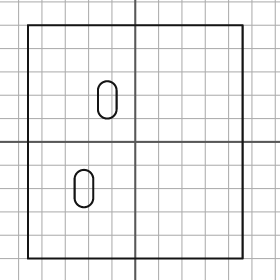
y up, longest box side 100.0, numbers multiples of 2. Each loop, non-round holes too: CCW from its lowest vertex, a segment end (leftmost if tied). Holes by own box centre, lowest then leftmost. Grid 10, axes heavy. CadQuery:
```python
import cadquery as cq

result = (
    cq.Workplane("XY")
    .moveTo(-46.0, -50.0)
    .lineTo(46.0, -50.0)
    .lineTo(46.0, 50.0)
    .lineTo(-46.0, 50.0)
    .close()
    .moveTo(-26.0, -24.0)
    .threePointArc((-22.0, -28.0), (-18.0, -24.0))
    .lineTo(-18.0, -16.0)
    .threePointArc((-22.0, -12.0), (-26.0, -16.0))
    .close()
    .moveTo(-16.0, 14.0)
    .threePointArc((-12.0, 10.0), (-8.0, 14.0))
    .lineTo(-8.0, 22.0)
    .threePointArc((-12.0, 26.0), (-16.0, 22.0))
    .close()
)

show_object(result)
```